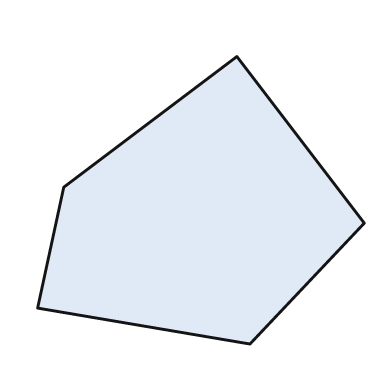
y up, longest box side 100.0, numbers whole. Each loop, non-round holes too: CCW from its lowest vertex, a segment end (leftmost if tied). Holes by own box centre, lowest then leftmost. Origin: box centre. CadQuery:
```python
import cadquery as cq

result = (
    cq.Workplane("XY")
    .moveTo(15.0, -44.0)
    .lineTo(50.0, -7.0)
    .lineTo(11.0, 44.0)
    .lineTo(-42.0, 4.0)
    .lineTo(-50.0, -33.0)
    .close()
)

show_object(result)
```